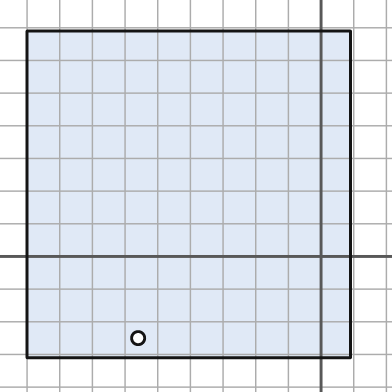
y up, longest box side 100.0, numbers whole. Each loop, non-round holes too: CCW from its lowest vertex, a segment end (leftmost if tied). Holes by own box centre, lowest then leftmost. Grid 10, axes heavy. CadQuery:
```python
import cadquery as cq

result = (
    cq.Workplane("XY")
    .moveTo(-90.0, -31.0)
    .lineTo(9.0, -31.0)
    .lineTo(9.0, 69.0)
    .lineTo(-90.0, 69.0)
    .close()
    .moveTo(-56.0, -25.0)
    .circle(2.0)
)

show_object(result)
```